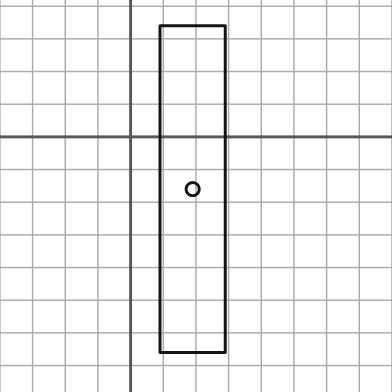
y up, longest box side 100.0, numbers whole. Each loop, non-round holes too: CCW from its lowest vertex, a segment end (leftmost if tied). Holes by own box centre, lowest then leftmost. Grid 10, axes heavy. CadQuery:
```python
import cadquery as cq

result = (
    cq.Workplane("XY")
    .moveTo(9.0, -66.0)
    .lineTo(29.0, -66.0)
    .lineTo(29.0, 34.0)
    .lineTo(9.0, 34.0)
    .close()
    .moveTo(19.0, -16.0)
    .circle(2.0)
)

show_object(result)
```